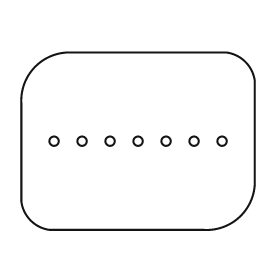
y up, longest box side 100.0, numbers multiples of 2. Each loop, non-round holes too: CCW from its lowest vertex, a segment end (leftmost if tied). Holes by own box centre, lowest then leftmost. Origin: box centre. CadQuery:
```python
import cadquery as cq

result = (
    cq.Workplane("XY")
    .moveTo(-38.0, -38.0)
    .lineTo(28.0, -38.0)
    .threePointArc((44.0, -32.0), (50.0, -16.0))
    .lineTo(50.0, 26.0)
    .threePointArc((46.0, 34.0), (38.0, 38.0))
    .lineTo(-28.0, 38.0)
    .threePointArc((-44.0, 32.0), (-50.0, 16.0))
    .lineTo(-50.0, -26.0)
    .threePointArc((-46.0, -34.0), (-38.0, -38.0))
    .close()
    .moveTo(-36.0, 0.0)
    .circle(2.0)
    .moveTo(-24.0, 0.0)
    .circle(2.0)
    .moveTo(-12.0, 0.0)
    .circle(2.0)
    .moveTo(0.0, 0.0)
    .circle(2.0)
    .moveTo(12.0, 0.0)
    .circle(2.0)
    .moveTo(24.0, 0.0)
    .circle(2.0)
    .moveTo(36.0, 0.0)
    .circle(2.0)
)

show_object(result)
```